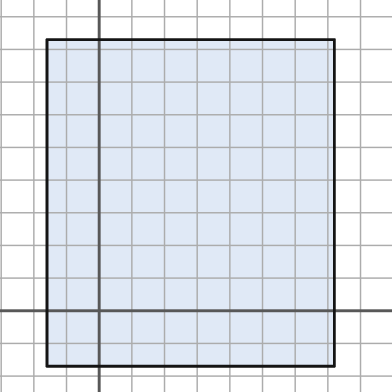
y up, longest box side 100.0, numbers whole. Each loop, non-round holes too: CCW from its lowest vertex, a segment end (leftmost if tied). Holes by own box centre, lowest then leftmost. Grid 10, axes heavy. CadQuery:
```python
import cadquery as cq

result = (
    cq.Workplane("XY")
    .moveTo(-16.0, -17.0)
    .lineTo(72.0, -17.0)
    .lineTo(72.0, 83.0)
    .lineTo(-16.0, 83.0)
    .close()
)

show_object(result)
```